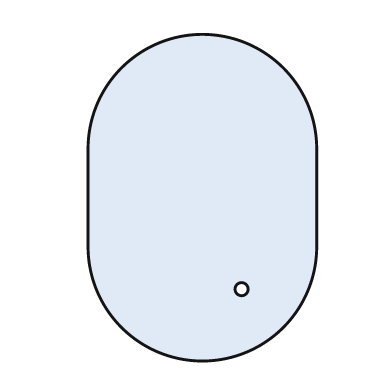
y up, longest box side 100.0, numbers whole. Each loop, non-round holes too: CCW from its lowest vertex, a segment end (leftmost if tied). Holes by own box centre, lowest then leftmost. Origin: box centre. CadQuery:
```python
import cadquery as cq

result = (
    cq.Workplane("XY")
    .moveTo(-35.0, -15.0)
    .threePointArc((0.0, -50.0), (35.0, -15.0))
    .lineTo(35.0, 15.0)
    .threePointArc((0.0, 50.0), (-35.0, 15.0))
    .close()
    .moveTo(12.0, -28.0)
    .circle(2.0)
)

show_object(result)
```